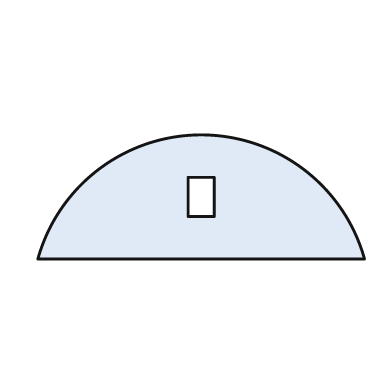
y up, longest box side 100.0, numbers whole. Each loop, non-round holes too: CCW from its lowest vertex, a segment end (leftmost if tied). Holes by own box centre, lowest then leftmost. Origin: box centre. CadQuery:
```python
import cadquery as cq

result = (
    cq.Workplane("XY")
    .moveTo(-50.0, -19.0)
    .lineTo(50.0, -19.0)
    .threePointArc((0.0, 19.0), (-50.0, -19.0))
    .close()
    .moveTo(-4.0, -6.0)
    .lineTo(4.0, -6.0)
    .lineTo(4.0, 6.0)
    .lineTo(-4.0, 6.0)
    .close()
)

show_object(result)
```